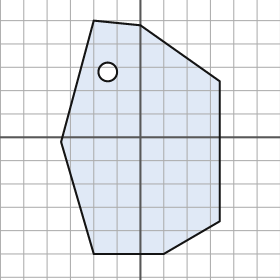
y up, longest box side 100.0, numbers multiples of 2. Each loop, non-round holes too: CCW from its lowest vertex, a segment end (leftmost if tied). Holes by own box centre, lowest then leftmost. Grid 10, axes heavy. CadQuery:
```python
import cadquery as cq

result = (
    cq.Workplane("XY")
    .moveTo(-20.0, -50.0)
    .lineTo(10.0, -50.0)
    .lineTo(34.0, -36.0)
    .lineTo(34.0, 24.0)
    .lineTo(0.0, 48.0)
    .lineTo(-20.0, 50.0)
    .lineTo(-34.0, -2.0)
    .close()
    .moveTo(-14.0, 28.0)
    .circle(4.0)
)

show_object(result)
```